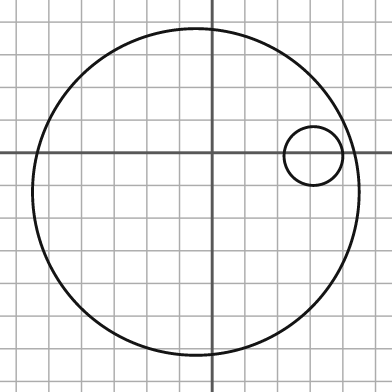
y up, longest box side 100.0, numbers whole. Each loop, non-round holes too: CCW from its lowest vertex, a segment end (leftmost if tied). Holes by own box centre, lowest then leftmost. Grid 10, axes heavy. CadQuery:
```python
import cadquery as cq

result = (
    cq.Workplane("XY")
    .moveTo(-5.0, -12.0)
    .circle(50.0)
    .moveTo(31.0, -1.0)
    .circle(9.0)
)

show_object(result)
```